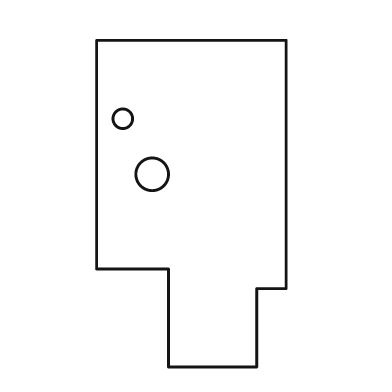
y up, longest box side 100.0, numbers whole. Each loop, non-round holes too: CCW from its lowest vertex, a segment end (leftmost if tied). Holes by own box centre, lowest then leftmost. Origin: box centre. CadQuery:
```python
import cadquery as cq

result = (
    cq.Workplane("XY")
    .moveTo(-7.0, -50.0)
    .lineTo(20.0, -50.0)
    .lineTo(20.0, -26.0)
    .lineTo(29.0, -26.0)
    .lineTo(29.0, 50.0)
    .lineTo(-29.0, 50.0)
    .lineTo(-29.0, -20.0)
    .lineTo(-7.0, -20.0)
    .close()
    .moveTo(-12.0, 9.0)
    .circle(5.0)
    .moveTo(-21.0, 26.0)
    .circle(3.0)
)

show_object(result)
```